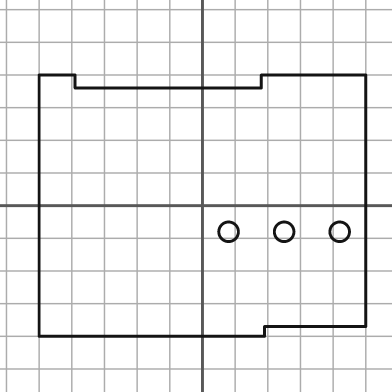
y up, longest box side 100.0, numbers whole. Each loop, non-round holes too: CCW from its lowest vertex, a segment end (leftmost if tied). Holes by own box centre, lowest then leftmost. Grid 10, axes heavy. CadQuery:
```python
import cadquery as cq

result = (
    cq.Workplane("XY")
    .moveTo(-50.0, -40.0)
    .lineTo(19.0, -40.0)
    .lineTo(19.0, -37.0)
    .lineTo(50.0, -37.0)
    .lineTo(50.0, 40.0)
    .lineTo(18.0, 40.0)
    .lineTo(18.0, 36.0)
    .lineTo(-39.0, 36.0)
    .lineTo(-39.0, 40.0)
    .lineTo(-50.0, 40.0)
    .close()
    .moveTo(8.0, -8.0)
    .circle(3.0)
    .moveTo(25.0, -8.0)
    .circle(3.0)
    .moveTo(42.0, -8.0)
    .circle(3.0)
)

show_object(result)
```